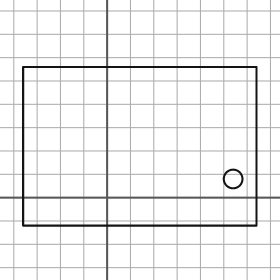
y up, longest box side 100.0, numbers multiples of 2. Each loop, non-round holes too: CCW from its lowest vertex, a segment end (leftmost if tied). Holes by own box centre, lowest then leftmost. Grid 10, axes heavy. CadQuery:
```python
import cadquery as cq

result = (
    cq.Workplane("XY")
    .moveTo(-36.0, -12.0)
    .lineTo(64.0, -12.0)
    .lineTo(64.0, 56.0)
    .lineTo(-36.0, 56.0)
    .close()
    .moveTo(54.0, 8.0)
    .circle(4.0)
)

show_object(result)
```